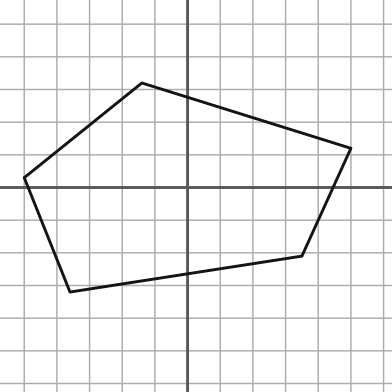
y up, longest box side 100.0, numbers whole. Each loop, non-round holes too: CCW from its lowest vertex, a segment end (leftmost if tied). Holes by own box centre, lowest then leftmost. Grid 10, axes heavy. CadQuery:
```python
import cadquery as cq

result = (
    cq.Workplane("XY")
    .moveTo(-36.0, -32.0)
    .lineTo(35.0, -21.0)
    .lineTo(50.0, 12.0)
    .lineTo(-14.0, 32.0)
    .lineTo(-50.0, 3.0)
    .close()
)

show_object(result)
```